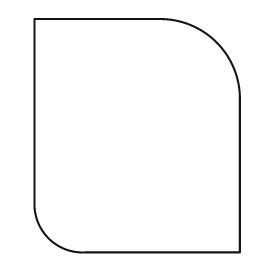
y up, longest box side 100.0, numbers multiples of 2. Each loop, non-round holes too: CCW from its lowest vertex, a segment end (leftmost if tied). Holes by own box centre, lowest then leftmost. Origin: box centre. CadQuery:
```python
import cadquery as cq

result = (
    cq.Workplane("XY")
    .moveTo(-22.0, -50.0)
    .lineTo(44.0, -50.0)
    .lineTo(44.0, 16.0)
    .threePointArc((34.0, 40.0), (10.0, 50.0))
    .lineTo(-44.0, 50.0)
    .lineTo(-44.0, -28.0)
    .threePointArc((-38.0, -44.0), (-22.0, -50.0))
    .close()
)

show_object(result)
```